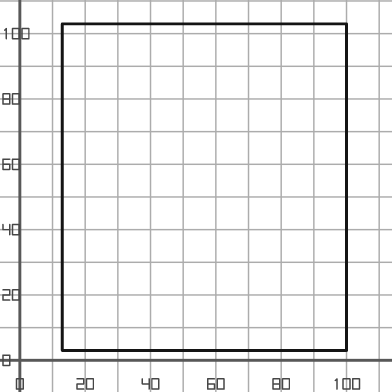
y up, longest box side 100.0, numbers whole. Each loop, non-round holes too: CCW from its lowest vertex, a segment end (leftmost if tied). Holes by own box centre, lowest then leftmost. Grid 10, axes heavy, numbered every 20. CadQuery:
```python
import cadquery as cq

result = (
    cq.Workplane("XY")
    .moveTo(13.0, 3.0)
    .lineTo(100.0, 3.0)
    .lineTo(100.0, 103.0)
    .lineTo(13.0, 103.0)
    .close()
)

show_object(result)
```